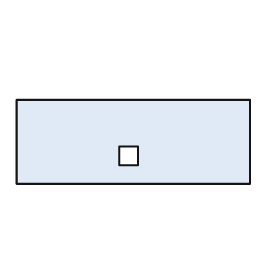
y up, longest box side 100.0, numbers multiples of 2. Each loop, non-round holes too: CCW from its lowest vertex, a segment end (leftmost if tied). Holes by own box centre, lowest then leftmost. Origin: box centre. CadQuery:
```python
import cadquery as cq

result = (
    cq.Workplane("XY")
    .moveTo(-50.0, -18.0)
    .lineTo(50.0, -18.0)
    .lineTo(50.0, 18.0)
    .lineTo(-50.0, 18.0)
    .close()
    .moveTo(-6.0, -10.0)
    .lineTo(2.0, -10.0)
    .lineTo(2.0, -2.0)
    .lineTo(-6.0, -2.0)
    .close()
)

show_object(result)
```